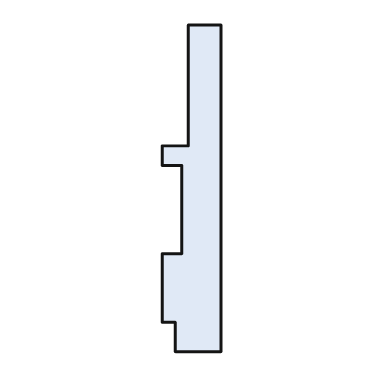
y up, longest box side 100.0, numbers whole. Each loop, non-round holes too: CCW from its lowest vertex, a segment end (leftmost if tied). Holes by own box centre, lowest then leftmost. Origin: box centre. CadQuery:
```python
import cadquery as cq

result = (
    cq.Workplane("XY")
    .moveTo(-5.0, -50.0)
    .lineTo(9.0, -50.0)
    .lineTo(9.0, 50.0)
    .lineTo(-1.0, 50.0)
    .lineTo(-1.0, 13.0)
    .lineTo(-9.0, 13.0)
    .lineTo(-9.0, 7.0)
    .lineTo(-3.0, 7.0)
    .lineTo(-3.0, -20.0)
    .lineTo(-9.0, -20.0)
    .lineTo(-9.0, -41.0)
    .lineTo(-5.0, -41.0)
    .close()
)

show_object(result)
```